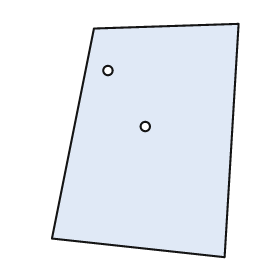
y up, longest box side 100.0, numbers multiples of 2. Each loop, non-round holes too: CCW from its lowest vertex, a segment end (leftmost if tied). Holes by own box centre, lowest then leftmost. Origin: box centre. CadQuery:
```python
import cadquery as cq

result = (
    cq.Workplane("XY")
    .moveTo(34.0, -50.0)
    .lineTo(40.0, 50.0)
    .lineTo(-22.0, 48.0)
    .lineTo(-40.0, -42.0)
    .close()
    .moveTo(0.0, 6.0)
    .circle(2.0)
    .moveTo(-16.0, 30.0)
    .circle(2.0)
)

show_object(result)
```